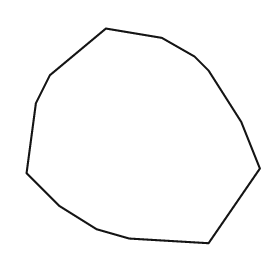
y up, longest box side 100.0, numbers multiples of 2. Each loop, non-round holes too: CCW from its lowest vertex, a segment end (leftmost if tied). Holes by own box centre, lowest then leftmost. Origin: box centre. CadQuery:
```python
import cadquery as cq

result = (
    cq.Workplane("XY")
    .moveTo(28.0, -46.0)
    .lineTo(50.0, -14.0)
    .lineTo(42.0, 6.0)
    .lineTo(28.0, 28.0)
    .lineTo(22.0, 34.0)
    .lineTo(8.0, 42.0)
    .lineTo(-16.0, 46.0)
    .lineTo(-40.0, 26.0)
    .lineTo(-46.0, 14.0)
    .lineTo(-50.0, -16.0)
    .lineTo(-36.0, -30.0)
    .lineTo(-20.0, -40.0)
    .lineTo(-6.0, -44.0)
    .close()
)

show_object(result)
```